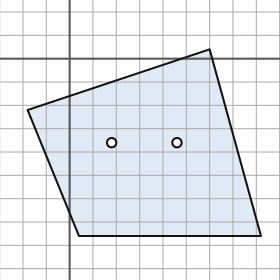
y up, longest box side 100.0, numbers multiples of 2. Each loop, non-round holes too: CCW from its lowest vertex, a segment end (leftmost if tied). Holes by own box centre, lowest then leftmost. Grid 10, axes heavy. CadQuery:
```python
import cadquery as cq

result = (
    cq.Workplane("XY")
    .moveTo(4.0, -76.0)
    .lineTo(82.0, -76.0)
    .lineTo(60.0, 4.0)
    .lineTo(-18.0, -22.0)
    .close()
    .moveTo(18.0, -36.0)
    .circle(2.0)
    .moveTo(46.0, -36.0)
    .circle(2.0)
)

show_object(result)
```